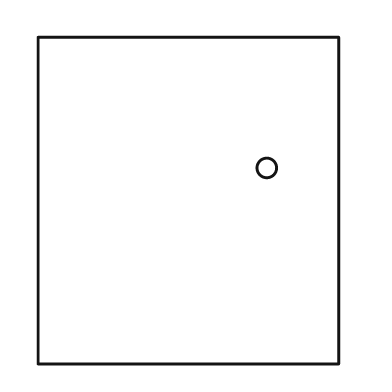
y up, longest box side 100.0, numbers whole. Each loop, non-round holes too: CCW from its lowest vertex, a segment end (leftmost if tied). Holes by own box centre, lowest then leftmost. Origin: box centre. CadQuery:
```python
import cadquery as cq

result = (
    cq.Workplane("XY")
    .moveTo(-46.0, -50.0)
    .lineTo(46.0, -50.0)
    .lineTo(46.0, 50.0)
    .lineTo(-46.0, 50.0)
    .close()
    .moveTo(24.0, 10.0)
    .circle(3.0)
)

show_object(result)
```